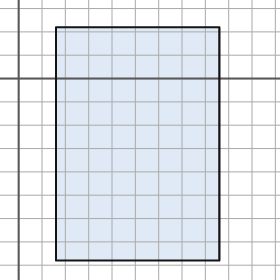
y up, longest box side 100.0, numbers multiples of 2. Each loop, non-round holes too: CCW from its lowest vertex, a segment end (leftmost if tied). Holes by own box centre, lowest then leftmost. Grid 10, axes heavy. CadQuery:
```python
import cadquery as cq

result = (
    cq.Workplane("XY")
    .moveTo(16.0, -78.0)
    .lineTo(86.0, -78.0)
    .lineTo(86.0, 22.0)
    .lineTo(16.0, 22.0)
    .close()
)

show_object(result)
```